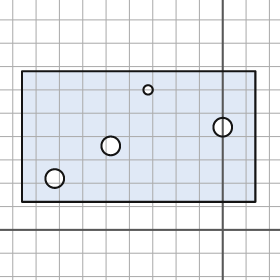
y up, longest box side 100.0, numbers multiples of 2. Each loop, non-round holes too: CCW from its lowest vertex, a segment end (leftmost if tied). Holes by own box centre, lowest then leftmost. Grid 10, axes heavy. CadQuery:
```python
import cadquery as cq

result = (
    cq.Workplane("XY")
    .moveTo(-86.0, 12.0)
    .lineTo(14.0, 12.0)
    .lineTo(14.0, 68.0)
    .lineTo(-86.0, 68.0)
    .close()
    .moveTo(-72.0, 22.0)
    .circle(4.0)
    .moveTo(-48.0, 36.0)
    .circle(4.0)
    .moveTo(0.0, 44.0)
    .circle(4.0)
    .moveTo(-32.0, 60.0)
    .circle(2.0)
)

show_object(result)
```